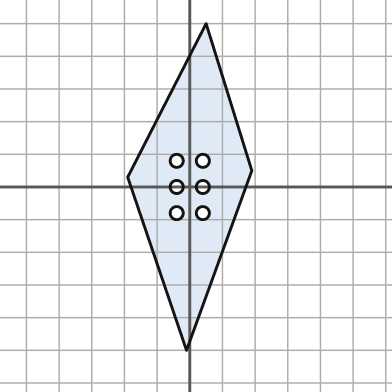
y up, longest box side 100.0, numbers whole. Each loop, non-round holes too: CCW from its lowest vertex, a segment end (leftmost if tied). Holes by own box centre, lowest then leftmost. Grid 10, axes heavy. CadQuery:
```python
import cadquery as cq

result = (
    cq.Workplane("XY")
    .moveTo(-1.0, -50.0)
    .lineTo(19.0, 5.0)
    .lineTo(5.0, 50.0)
    .lineTo(-19.0, 3.0)
    .close()
    .moveTo(-4.0, -8.0)
    .circle(2.0)
    .moveTo(4.0, -8.0)
    .circle(2.0)
    .moveTo(-4.0, 0.0)
    .circle(2.0)
    .moveTo(4.0, 0.0)
    .circle(2.0)
    .moveTo(-4.0, 8.0)
    .circle(2.0)
    .moveTo(4.0, 8.0)
    .circle(2.0)
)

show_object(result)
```